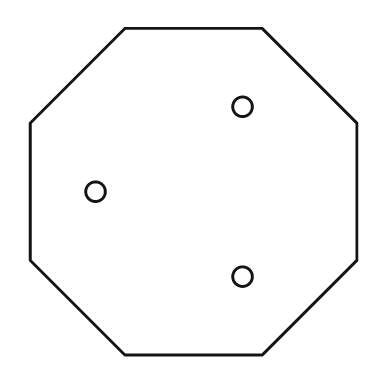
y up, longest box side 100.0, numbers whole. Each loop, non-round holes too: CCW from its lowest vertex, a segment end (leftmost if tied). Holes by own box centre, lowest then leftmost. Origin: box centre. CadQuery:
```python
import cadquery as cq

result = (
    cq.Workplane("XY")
    .moveTo(-21.0, -50.0)
    .lineTo(21.0, -50.0)
    .lineTo(50.0, -21.0)
    .lineTo(50.0, 21.0)
    .lineTo(21.0, 50.0)
    .lineTo(-21.0, 50.0)
    .lineTo(-50.0, 21.0)
    .lineTo(-50.0, -21.0)
    .close()
    .moveTo(15.0, -26.0)
    .circle(3.0)
    .moveTo(-30.0, 0.0)
    .circle(3.0)
    .moveTo(15.0, 26.0)
    .circle(3.0)
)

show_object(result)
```